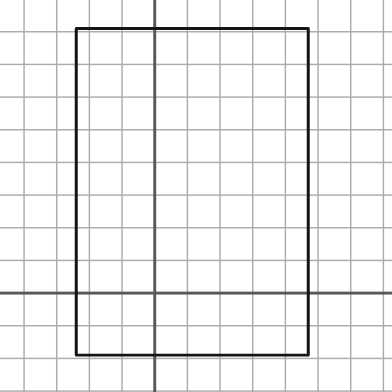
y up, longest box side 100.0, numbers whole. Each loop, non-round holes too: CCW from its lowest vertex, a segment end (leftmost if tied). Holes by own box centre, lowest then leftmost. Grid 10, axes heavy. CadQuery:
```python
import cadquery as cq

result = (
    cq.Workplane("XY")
    .moveTo(-24.0, -19.0)
    .lineTo(47.0, -19.0)
    .lineTo(47.0, 81.0)
    .lineTo(-24.0, 81.0)
    .close()
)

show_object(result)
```